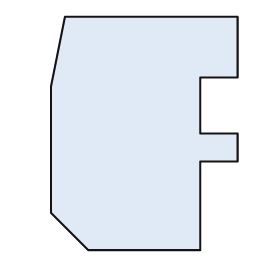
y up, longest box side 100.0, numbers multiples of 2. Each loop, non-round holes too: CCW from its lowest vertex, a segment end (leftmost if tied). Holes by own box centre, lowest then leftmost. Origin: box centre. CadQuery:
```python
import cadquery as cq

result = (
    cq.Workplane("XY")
    .moveTo(-24.0, -50.0)
    .lineTo(24.0, -50.0)
    .lineTo(24.0, -12.0)
    .lineTo(40.0, -12.0)
    .lineTo(40.0, 0.0)
    .lineTo(24.0, 0.0)
    .lineTo(24.0, 24.0)
    .lineTo(40.0, 24.0)
    .lineTo(40.0, 50.0)
    .lineTo(-34.0, 50.0)
    .lineTo(-40.0, 20.0)
    .lineTo(-40.0, -34.0)
    .close()
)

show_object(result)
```